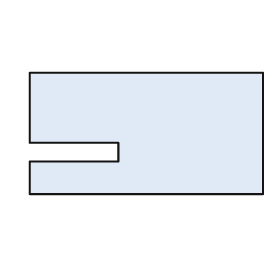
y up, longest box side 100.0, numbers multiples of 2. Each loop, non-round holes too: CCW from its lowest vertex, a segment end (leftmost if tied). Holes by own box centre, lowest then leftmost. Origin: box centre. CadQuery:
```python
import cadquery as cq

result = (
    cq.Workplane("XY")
    .moveTo(-50.0, -26.0)
    .lineTo(50.0, -26.0)
    .lineTo(50.0, 26.0)
    .lineTo(-50.0, 26.0)
    .lineTo(-50.0, -4.0)
    .lineTo(-12.0, -4.0)
    .lineTo(-12.0, -12.0)
    .lineTo(-50.0, -12.0)
    .close()
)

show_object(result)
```